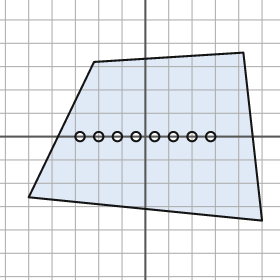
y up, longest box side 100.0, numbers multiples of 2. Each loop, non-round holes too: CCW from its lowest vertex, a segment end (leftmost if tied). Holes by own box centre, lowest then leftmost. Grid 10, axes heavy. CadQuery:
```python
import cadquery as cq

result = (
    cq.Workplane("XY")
    .moveTo(50.0, -36.0)
    .lineTo(42.0, 36.0)
    .lineTo(-22.0, 32.0)
    .lineTo(-50.0, -26.0)
    .close()
    .moveTo(-28.0, 0.0)
    .circle(2.0)
    .moveTo(-20.0, 0.0)
    .circle(2.0)
    .moveTo(-12.0, 0.0)
    .circle(2.0)
    .moveTo(-4.0, 0.0)
    .circle(2.0)
    .moveTo(4.0, 0.0)
    .circle(2.0)
    .moveTo(12.0, 0.0)
    .circle(2.0)
    .moveTo(20.0, 0.0)
    .circle(2.0)
    .moveTo(28.0, 0.0)
    .circle(2.0)
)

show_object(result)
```